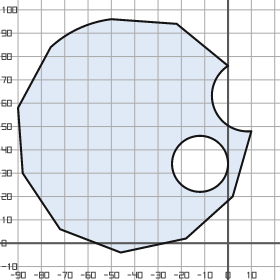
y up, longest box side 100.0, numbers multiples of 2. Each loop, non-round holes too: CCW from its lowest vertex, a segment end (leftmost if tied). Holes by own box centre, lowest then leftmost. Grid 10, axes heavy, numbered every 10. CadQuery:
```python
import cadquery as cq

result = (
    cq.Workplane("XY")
    .moveTo(-46.0, -4.0)
    .lineTo(-18.0, 2.0)
    .lineTo(2.0, 20.0)
    .lineTo(10.0, 48.0)
    .threePointArc((-6.0, 58.0), (0.0, 76.0))
    .lineTo(-22.0, 94.0)
    .lineTo(-50.0, 96.0)
    .threePointArc((-64.0, 92.0), (-76.0, 84.0))
    .lineTo(-90.0, 58.0)
    .lineTo(-88.0, 30.0)
    .lineTo(-72.0, 6.0)
    .close()
    .moveTo(-12.0, 34.0)
    .circle(12.0)
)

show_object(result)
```